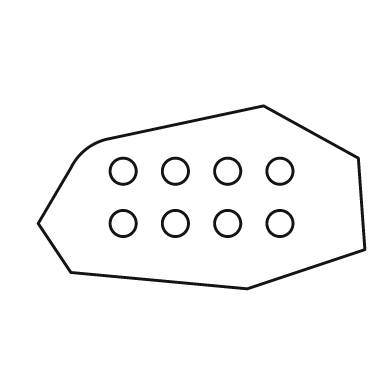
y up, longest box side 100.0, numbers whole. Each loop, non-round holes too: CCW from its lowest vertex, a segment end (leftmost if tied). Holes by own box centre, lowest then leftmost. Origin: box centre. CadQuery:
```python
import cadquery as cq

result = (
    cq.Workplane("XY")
    .moveTo(14.0, -28.0)
    .lineTo(50.0, -16.0)
    .lineTo(48.0, 12.0)
    .lineTo(19.0, 28.0)
    .lineTo(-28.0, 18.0)
    .threePointArc((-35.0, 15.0), (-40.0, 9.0))
    .lineTo(-50.0, -8.0)
    .lineTo(-40.0, -23.0)
    .close()
    .moveTo(-24.0, -8.0)
    .circle(4.0)
    .moveTo(-8.0, -8.0)
    .circle(4.0)
    .moveTo(8.0, -8.0)
    .circle(4.0)
    .moveTo(24.0, -8.0)
    .circle(4.0)
    .moveTo(-24.0, 8.0)
    .circle(4.0)
    .moveTo(-8.0, 8.0)
    .circle(4.0)
    .moveTo(8.0, 8.0)
    .circle(4.0)
    .moveTo(24.0, 8.0)
    .circle(4.0)
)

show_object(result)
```